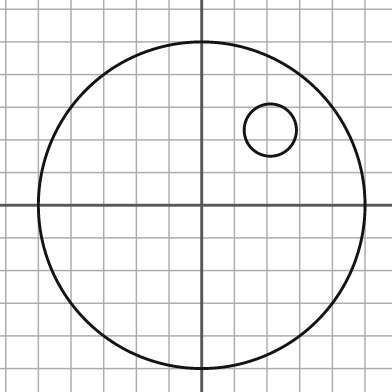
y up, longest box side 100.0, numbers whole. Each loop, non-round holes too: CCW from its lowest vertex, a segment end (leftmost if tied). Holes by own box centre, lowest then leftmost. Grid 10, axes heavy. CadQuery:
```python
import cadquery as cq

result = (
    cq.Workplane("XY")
    .moveTo(0.0, 0.0)
    .circle(50.0)
    .moveTo(21.0, 23.0)
    .circle(8.0)
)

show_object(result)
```